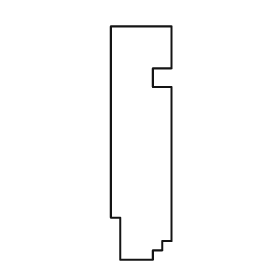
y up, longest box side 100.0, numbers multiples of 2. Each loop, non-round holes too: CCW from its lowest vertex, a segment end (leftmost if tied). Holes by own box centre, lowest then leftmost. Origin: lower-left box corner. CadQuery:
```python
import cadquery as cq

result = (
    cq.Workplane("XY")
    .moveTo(4.0, 0.0)
    .lineTo(18.0, 0.0)
    .lineTo(18.0, 4.0)
    .lineTo(22.0, 4.0)
    .lineTo(22.0, 8.0)
    .lineTo(26.0, 8.0)
    .lineTo(26.0, 74.0)
    .lineTo(18.0, 74.0)
    .lineTo(18.0, 82.0)
    .lineTo(26.0, 82.0)
    .lineTo(26.0, 100.0)
    .lineTo(0.0, 100.0)
    .lineTo(0.0, 18.0)
    .lineTo(4.0, 18.0)
    .close()
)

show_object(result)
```